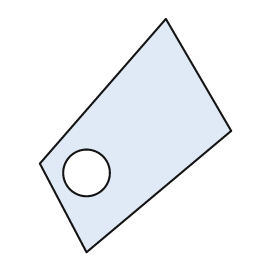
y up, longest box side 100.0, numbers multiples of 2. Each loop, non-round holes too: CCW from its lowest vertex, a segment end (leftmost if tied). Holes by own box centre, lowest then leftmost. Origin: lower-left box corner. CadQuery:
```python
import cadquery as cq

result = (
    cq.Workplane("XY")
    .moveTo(20.0, 0.0)
    .lineTo(82.0, 52.0)
    .lineTo(54.0, 100.0)
    .lineTo(0.0, 38.0)
    .close()
    .moveTo(20.0, 34.0)
    .circle(10.0)
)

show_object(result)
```